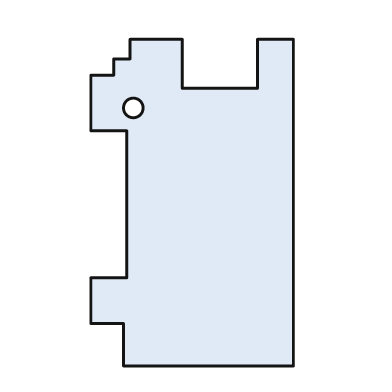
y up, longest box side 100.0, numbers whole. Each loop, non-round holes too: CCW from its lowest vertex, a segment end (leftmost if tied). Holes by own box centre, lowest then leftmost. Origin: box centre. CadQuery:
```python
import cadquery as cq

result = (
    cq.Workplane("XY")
    .moveTo(-21.0, -50.0)
    .lineTo(31.0, -50.0)
    .lineTo(31.0, 50.0)
    .lineTo(20.0, 50.0)
    .lineTo(20.0, 35.0)
    .lineTo(-3.0, 35.0)
    .lineTo(-3.0, 50.0)
    .lineTo(-19.0, 50.0)
    .lineTo(-19.0, 44.0)
    .lineTo(-24.0, 44.0)
    .lineTo(-24.0, 39.0)
    .lineTo(-31.0, 39.0)
    .lineTo(-31.0, 22.0)
    .lineTo(-20.0, 22.0)
    .lineTo(-20.0, -23.0)
    .lineTo(-31.0, -23.0)
    .lineTo(-31.0, -37.0)
    .lineTo(-21.0, -37.0)
    .close()
    .moveTo(-18.0, 29.0)
    .circle(3.0)
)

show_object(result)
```